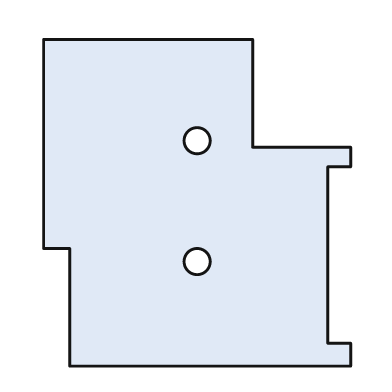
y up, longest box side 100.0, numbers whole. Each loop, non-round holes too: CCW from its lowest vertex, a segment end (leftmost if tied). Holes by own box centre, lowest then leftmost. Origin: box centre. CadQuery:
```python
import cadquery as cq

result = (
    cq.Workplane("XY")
    .moveTo(-39.0, -50.0)
    .lineTo(47.0, -50.0)
    .lineTo(47.0, -43.0)
    .lineTo(40.0, -43.0)
    .lineTo(40.0, 11.0)
    .lineTo(47.0, 11.0)
    .lineTo(47.0, 17.0)
    .lineTo(17.0, 17.0)
    .lineTo(17.0, 50.0)
    .lineTo(-47.0, 50.0)
    .lineTo(-47.0, -14.0)
    .lineTo(-39.0, -14.0)
    .close()
    .moveTo(0.0, -18.0)
    .circle(4.0)
    .moveTo(0.0, 19.0)
    .circle(4.0)
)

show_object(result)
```